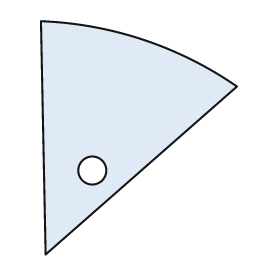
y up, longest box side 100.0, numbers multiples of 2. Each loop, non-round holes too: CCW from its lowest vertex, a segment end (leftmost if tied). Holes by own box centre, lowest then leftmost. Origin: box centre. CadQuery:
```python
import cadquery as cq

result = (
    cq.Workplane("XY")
    .moveTo(-40.0, -50.0)
    .lineTo(42.0, 22.0)
    .threePointArc((2.0, 42.0), (-42.0, 50.0))
    .close()
    .moveTo(-20.0, -14.0)
    .circle(6.0)
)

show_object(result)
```